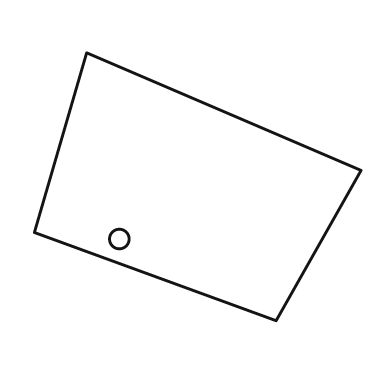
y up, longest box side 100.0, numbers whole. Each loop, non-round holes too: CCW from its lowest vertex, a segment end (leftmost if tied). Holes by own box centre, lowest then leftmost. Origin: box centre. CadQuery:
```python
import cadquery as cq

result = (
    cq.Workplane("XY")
    .moveTo(24.0, -41.0)
    .lineTo(50.0, 5.0)
    .lineTo(-34.0, 41.0)
    .lineTo(-50.0, -14.0)
    .close()
    .moveTo(-24.0, -16.0)
    .circle(3.0)
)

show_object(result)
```